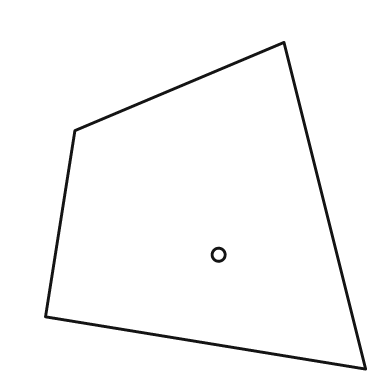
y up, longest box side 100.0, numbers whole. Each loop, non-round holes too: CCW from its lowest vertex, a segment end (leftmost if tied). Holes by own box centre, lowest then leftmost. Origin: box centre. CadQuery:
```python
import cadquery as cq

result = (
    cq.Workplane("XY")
    .moveTo(49.0, -50.0)
    .lineTo(24.0, 50.0)
    .lineTo(-40.0, 23.0)
    .lineTo(-49.0, -34.0)
    .close()
    .moveTo(4.0, -15.0)
    .circle(2.0)
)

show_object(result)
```